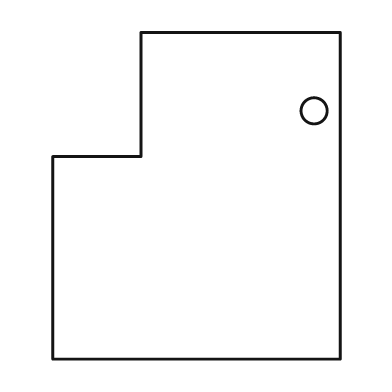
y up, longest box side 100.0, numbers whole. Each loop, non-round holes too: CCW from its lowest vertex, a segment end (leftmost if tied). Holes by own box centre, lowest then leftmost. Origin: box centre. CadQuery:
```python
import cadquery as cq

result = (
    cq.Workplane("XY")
    .moveTo(-44.0, -50.0)
    .lineTo(44.0, -50.0)
    .lineTo(44.0, 50.0)
    .lineTo(-17.0, 50.0)
    .lineTo(-17.0, 12.0)
    .lineTo(-44.0, 12.0)
    .close()
    .moveTo(36.0, 26.0)
    .circle(4.0)
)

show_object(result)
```